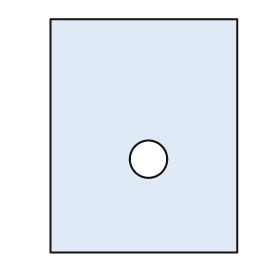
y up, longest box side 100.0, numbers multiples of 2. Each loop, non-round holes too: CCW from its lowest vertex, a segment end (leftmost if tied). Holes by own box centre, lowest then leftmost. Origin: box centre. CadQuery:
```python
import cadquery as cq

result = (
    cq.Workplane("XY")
    .moveTo(-40.0, -50.0)
    .lineTo(40.0, -50.0)
    .lineTo(40.0, 50.0)
    .lineTo(-40.0, 50.0)
    .close()
    .moveTo(2.0, -10.0)
    .circle(8.0)
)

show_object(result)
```